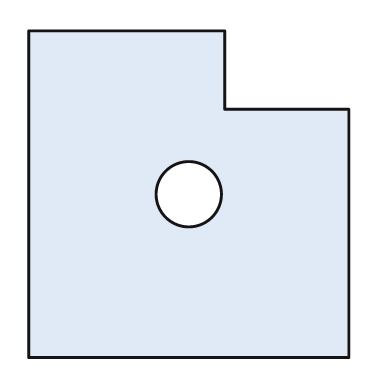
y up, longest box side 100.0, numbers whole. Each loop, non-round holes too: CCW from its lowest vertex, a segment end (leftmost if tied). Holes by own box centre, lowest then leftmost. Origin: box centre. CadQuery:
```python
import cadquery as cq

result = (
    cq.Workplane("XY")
    .moveTo(-49.0, -50.0)
    .lineTo(49.0, -50.0)
    .lineTo(49.0, 26.0)
    .lineTo(11.0, 26.0)
    .lineTo(11.0, 50.0)
    .lineTo(-49.0, 50.0)
    .close()
    .moveTo(0.0, 0.0)
    .circle(10.0)
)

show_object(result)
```